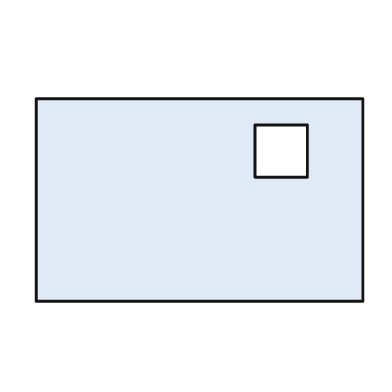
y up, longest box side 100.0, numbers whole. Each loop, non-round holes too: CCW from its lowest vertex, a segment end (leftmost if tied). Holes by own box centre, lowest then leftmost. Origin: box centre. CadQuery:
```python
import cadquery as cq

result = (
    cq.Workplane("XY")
    .moveTo(-50.0, -31.0)
    .lineTo(50.0, -31.0)
    .lineTo(50.0, 31.0)
    .lineTo(-50.0, 31.0)
    .close()
    .moveTo(17.0, 7.0)
    .lineTo(33.0, 7.0)
    .lineTo(33.0, 23.0)
    .lineTo(17.0, 23.0)
    .close()
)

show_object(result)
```